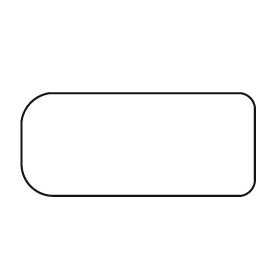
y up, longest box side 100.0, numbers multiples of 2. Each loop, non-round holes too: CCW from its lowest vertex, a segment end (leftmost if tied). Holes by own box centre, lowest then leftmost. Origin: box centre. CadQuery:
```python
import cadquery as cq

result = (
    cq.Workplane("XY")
    .moveTo(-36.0, -22.0)
    .lineTo(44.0, -22.0)
    .threePointArc((48.0, -20.0), (50.0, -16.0))
    .lineTo(50.0, 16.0)
    .threePointArc((48.0, 20.0), (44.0, 22.0))
    .lineTo(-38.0, 22.0)
    .threePointArc((-46.0, 18.0), (-50.0, 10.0))
    .lineTo(-50.0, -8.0)
    .threePointArc((-46.0, -18.0), (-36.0, -22.0))
    .close()
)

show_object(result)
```